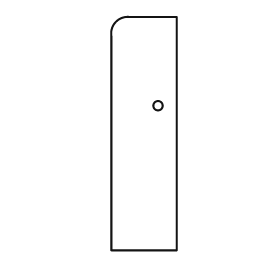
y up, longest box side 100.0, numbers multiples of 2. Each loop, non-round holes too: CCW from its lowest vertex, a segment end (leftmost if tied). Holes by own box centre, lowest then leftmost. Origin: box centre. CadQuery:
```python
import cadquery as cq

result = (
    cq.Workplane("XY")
    .moveTo(-14.0, -50.0)
    .lineTo(14.0, -50.0)
    .lineTo(14.0, 50.0)
    .lineTo(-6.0, 50.0)
    .threePointArc((-12.0, 48.0), (-14.0, 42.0))
    .close()
    .moveTo(6.0, 12.0)
    .circle(2.0)
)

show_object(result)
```